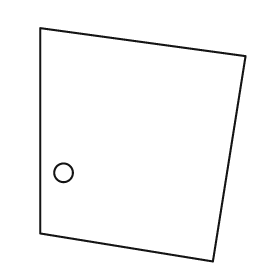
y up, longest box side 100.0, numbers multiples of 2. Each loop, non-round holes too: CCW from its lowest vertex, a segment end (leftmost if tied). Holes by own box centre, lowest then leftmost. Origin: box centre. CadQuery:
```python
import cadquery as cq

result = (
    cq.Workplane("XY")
    .moveTo(30.0, -50.0)
    .lineTo(44.0, 38.0)
    .lineTo(-44.0, 50.0)
    .lineTo(-44.0, -38.0)
    .close()
    .moveTo(-34.0, -12.0)
    .circle(4.0)
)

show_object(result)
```